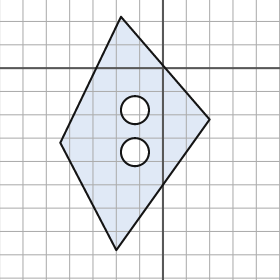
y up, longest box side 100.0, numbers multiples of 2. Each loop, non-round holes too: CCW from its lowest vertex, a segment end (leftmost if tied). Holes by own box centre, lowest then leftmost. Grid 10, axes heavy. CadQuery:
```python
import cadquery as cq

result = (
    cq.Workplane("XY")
    .moveTo(-20.0, -78.0)
    .lineTo(20.0, -22.0)
    .lineTo(-18.0, 22.0)
    .lineTo(-44.0, -32.0)
    .close()
    .moveTo(-12.0, -36.0)
    .circle(6.0)
    .moveTo(-12.0, -18.0)
    .circle(6.0)
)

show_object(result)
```